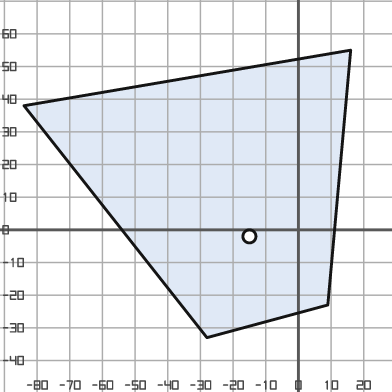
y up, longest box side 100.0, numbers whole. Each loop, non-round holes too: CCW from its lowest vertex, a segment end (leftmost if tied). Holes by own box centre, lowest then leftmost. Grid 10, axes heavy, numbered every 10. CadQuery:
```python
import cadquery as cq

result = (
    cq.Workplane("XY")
    .moveTo(-28.0, -33.0)
    .lineTo(9.0, -23.0)
    .lineTo(16.0, 55.0)
    .lineTo(-84.0, 38.0)
    .close()
    .moveTo(-15.0, -2.0)
    .circle(2.0)
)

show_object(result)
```